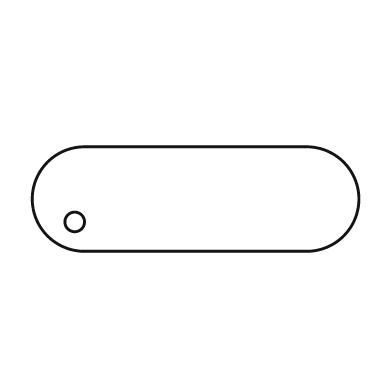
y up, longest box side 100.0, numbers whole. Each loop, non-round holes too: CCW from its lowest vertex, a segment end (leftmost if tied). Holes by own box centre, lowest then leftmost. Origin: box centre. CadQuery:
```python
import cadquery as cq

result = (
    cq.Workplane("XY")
    .moveTo(-34.0, -16.0)
    .lineTo(34.0, -16.0)
    .threePointArc((50.0, 0.0), (34.0, 16.0))
    .lineTo(-34.0, 16.0)
    .threePointArc((-50.0, 0.0), (-34.0, -16.0))
    .close()
    .moveTo(-37.0, -7.0)
    .circle(3.0)
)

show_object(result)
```